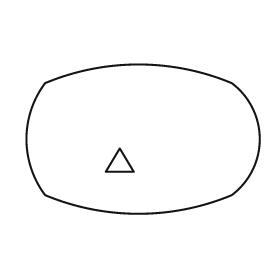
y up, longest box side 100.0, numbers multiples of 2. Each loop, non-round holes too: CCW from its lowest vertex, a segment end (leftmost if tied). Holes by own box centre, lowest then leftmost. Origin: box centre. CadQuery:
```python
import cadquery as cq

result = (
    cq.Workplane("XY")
    .moveTo(-42.0, -24.0)
    .threePointArc((-2.0, -32.0), (38.0, -24.0))
    .threePointArc((50.0, 0.0), (38.0, 24.0))
    .threePointArc((-2.0, 32.0), (-42.0, 24.0))
    .threePointArc((-50.0, 0.0), (-42.0, -24.0))
    .close()
    .moveTo(-16.0, -14.0)
    .lineTo(-4.0, -14.0)
    .lineTo(-10.0, -4.0)
    .close()
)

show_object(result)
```